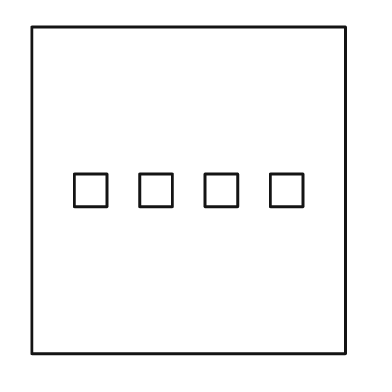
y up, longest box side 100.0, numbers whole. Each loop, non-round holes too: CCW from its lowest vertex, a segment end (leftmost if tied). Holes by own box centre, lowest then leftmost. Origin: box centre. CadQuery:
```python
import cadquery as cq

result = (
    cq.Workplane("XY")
    .moveTo(-48.0, -50.0)
    .lineTo(48.0, -50.0)
    .lineTo(48.0, 50.0)
    .lineTo(-48.0, 50.0)
    .close()
    .moveTo(-35.0, -5.0)
    .lineTo(-25.0, -5.0)
    .lineTo(-25.0, 5.0)
    .lineTo(-35.0, 5.0)
    .close()
    .moveTo(-15.0, -5.0)
    .lineTo(-5.0, -5.0)
    .lineTo(-5.0, 5.0)
    .lineTo(-15.0, 5.0)
    .close()
    .moveTo(5.0, -5.0)
    .lineTo(15.0, -5.0)
    .lineTo(15.0, 5.0)
    .lineTo(5.0, 5.0)
    .close()
    .moveTo(25.0, -5.0)
    .lineTo(35.0, -5.0)
    .lineTo(35.0, 5.0)
    .lineTo(25.0, 5.0)
    .close()
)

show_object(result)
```